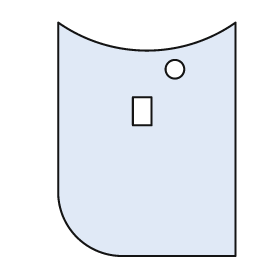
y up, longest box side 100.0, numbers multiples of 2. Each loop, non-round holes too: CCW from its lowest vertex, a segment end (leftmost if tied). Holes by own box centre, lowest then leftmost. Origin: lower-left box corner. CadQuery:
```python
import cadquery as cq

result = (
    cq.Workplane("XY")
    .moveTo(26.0, 0.0)
    .lineTo(76.0, 0.0)
    .lineTo(76.0, 100.0)
    .threePointArc((38.0, 88.0), (0.0, 100.0))
    .lineTo(0.0, 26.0)
    .threePointArc((8.0, 8.0), (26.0, 0.0))
    .close()
    .moveTo(32.0, 56.0)
    .lineTo(40.0, 56.0)
    .lineTo(40.0, 68.0)
    .lineTo(32.0, 68.0)
    .close()
    .moveTo(50.0, 80.0)
    .circle(4.0)
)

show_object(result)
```